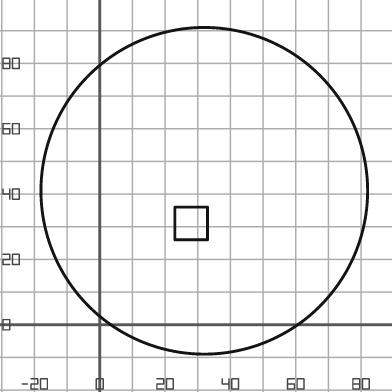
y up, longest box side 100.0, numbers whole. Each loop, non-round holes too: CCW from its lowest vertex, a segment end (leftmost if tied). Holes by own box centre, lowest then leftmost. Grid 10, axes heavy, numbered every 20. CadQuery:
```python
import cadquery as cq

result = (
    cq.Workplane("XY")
    .moveTo(32.0, 41.0)
    .circle(50.0)
    .moveTo(23.0, 26.0)
    .lineTo(33.0, 26.0)
    .lineTo(33.0, 36.0)
    .lineTo(23.0, 36.0)
    .close()
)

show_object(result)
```